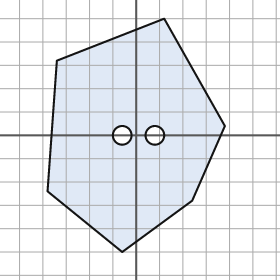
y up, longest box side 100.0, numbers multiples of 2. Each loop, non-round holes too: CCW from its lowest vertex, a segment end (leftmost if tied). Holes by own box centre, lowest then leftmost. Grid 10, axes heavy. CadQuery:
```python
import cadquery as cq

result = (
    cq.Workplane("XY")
    .moveTo(-6.0, -50.0)
    .lineTo(24.0, -28.0)
    .lineTo(38.0, 4.0)
    .lineTo(12.0, 50.0)
    .lineTo(-34.0, 32.0)
    .lineTo(-38.0, -24.0)
    .close()
    .moveTo(-6.0, 0.0)
    .circle(4.0)
    .moveTo(8.0, 0.0)
    .circle(4.0)
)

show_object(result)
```